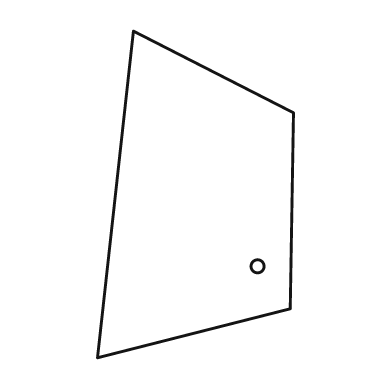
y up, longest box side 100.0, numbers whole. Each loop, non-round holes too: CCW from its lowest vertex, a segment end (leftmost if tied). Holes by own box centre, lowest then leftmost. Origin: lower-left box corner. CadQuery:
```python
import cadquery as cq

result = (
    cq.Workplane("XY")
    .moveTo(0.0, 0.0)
    .lineTo(59.0, 15.0)
    .lineTo(60.0, 75.0)
    .lineTo(11.0, 100.0)
    .close()
    .moveTo(49.0, 28.0)
    .circle(2.0)
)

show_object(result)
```